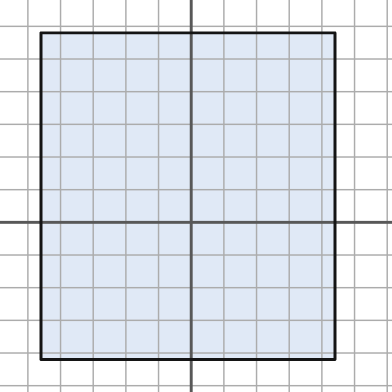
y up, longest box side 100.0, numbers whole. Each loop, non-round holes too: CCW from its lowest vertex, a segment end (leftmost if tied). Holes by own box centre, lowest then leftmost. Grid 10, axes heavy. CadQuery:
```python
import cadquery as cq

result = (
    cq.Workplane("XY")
    .moveTo(-46.0, -42.0)
    .lineTo(44.0, -42.0)
    .lineTo(44.0, 58.0)
    .lineTo(-46.0, 58.0)
    .close()
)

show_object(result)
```